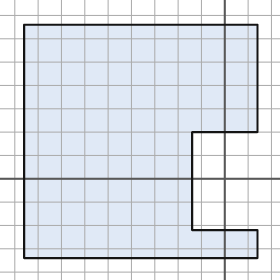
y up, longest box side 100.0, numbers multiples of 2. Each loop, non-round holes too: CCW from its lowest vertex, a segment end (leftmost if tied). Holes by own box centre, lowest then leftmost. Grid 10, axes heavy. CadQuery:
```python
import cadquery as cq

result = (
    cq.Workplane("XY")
    .moveTo(-86.0, -34.0)
    .lineTo(14.0, -34.0)
    .lineTo(14.0, -22.0)
    .lineTo(-14.0, -22.0)
    .lineTo(-14.0, 20.0)
    .lineTo(14.0, 20.0)
    .lineTo(14.0, 66.0)
    .lineTo(-86.0, 66.0)
    .close()
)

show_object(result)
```